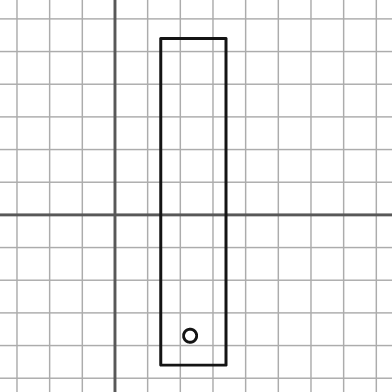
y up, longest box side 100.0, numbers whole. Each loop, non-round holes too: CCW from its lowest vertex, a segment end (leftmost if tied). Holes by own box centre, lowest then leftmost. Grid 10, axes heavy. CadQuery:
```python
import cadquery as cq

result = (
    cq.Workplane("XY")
    .moveTo(14.0, -46.0)
    .lineTo(34.0, -46.0)
    .lineTo(34.0, 54.0)
    .lineTo(14.0, 54.0)
    .close()
    .moveTo(23.0, -37.0)
    .circle(2.0)
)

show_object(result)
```